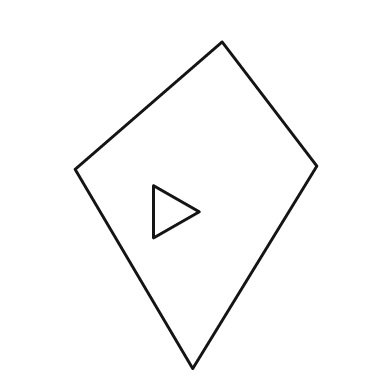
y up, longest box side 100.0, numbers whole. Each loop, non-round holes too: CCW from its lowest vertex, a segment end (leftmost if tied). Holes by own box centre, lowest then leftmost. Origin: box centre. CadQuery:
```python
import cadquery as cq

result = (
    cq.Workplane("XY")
    .moveTo(-1.0, -50.0)
    .lineTo(37.0, 12.0)
    .lineTo(8.0, 50.0)
    .lineTo(-37.0, 11.0)
    .close()
    .moveTo(-13.0, -10.0)
    .lineTo(1.0, -2.0)
    .lineTo(-13.0, 6.0)
    .close()
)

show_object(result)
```